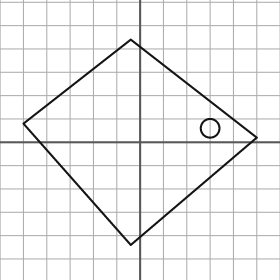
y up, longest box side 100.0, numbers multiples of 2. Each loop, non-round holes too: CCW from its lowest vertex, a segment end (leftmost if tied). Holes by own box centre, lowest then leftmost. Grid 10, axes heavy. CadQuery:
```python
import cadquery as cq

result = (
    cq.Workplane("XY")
    .moveTo(-4.0, -44.0)
    .lineTo(50.0, 2.0)
    .lineTo(-4.0, 44.0)
    .lineTo(-50.0, 8.0)
    .close()
    .moveTo(30.0, 6.0)
    .circle(4.0)
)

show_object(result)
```